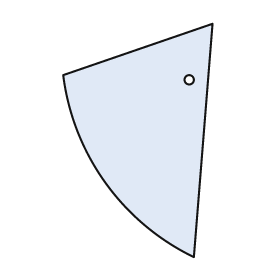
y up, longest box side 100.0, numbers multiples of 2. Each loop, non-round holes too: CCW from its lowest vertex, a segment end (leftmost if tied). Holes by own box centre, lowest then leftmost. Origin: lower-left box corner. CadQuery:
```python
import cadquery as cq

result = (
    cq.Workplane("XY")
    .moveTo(56.0, 0.0)
    .lineTo(64.0, 100.0)
    .lineTo(0.0, 78.0)
    .threePointArc((18.0, 32.0), (56.0, 0.0))
    .close()
    .moveTo(54.0, 76.0)
    .circle(2.0)
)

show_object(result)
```